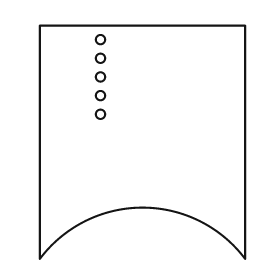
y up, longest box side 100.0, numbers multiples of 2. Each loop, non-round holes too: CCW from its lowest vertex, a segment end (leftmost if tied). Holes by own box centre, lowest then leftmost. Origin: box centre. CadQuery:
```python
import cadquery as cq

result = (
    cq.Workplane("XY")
    .moveTo(-44.0, -50.0)
    .threePointArc((0.0, -28.0), (44.0, -50.0))
    .lineTo(44.0, 50.0)
    .lineTo(-44.0, 50.0)
    .close()
    .moveTo(-18.0, 12.0)
    .circle(2.0)
    .moveTo(-18.0, 20.0)
    .circle(2.0)
    .moveTo(-18.0, 28.0)
    .circle(2.0)
    .moveTo(-18.0, 36.0)
    .circle(2.0)
    .moveTo(-18.0, 44.0)
    .circle(2.0)
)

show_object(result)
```